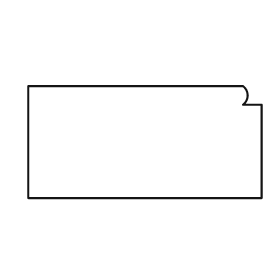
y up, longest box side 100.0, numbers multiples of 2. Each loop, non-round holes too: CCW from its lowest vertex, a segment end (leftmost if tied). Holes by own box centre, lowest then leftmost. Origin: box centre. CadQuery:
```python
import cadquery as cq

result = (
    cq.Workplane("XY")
    .moveTo(-50.0, -24.0)
    .lineTo(50.0, -24.0)
    .lineTo(50.0, 16.0)
    .lineTo(42.0, 16.0)
    .threePointArc((44.0, 20.0), (42.0, 24.0))
    .lineTo(-50.0, 24.0)
    .close()
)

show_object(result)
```